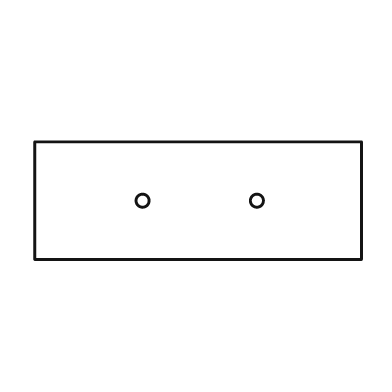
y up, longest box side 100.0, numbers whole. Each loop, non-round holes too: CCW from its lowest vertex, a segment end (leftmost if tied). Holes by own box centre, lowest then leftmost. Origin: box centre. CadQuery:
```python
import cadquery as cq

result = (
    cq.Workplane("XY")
    .moveTo(-50.0, -18.0)
    .lineTo(50.0, -18.0)
    .lineTo(50.0, 18.0)
    .lineTo(-50.0, 18.0)
    .close()
    .moveTo(-17.0, 0.0)
    .circle(2.0)
    .moveTo(18.0, 0.0)
    .circle(2.0)
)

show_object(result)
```